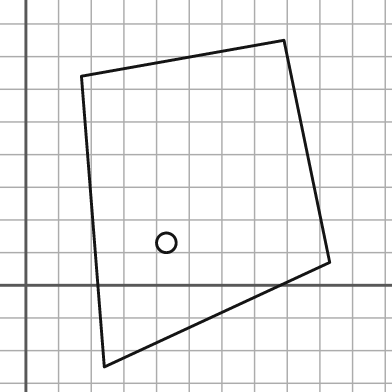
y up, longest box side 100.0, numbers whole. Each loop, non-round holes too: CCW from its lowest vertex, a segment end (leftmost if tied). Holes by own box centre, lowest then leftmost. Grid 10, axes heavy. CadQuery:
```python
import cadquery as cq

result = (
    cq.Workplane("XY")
    .moveTo(24.0, -25.0)
    .lineTo(93.0, 7.0)
    .lineTo(79.0, 75.0)
    .lineTo(17.0, 64.0)
    .close()
    .moveTo(43.0, 13.0)
    .circle(3.0)
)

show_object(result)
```